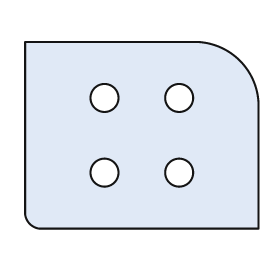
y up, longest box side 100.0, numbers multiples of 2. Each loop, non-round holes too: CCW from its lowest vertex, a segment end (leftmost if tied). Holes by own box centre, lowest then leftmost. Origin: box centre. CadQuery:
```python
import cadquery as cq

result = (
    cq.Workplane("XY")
    .moveTo(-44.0, -40.0)
    .lineTo(50.0, -40.0)
    .lineTo(50.0, 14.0)
    .threePointArc((42.0, 32.0), (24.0, 40.0))
    .lineTo(-50.0, 40.0)
    .lineTo(-50.0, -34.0)
    .threePointArc((-48.0, -38.0), (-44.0, -40.0))
    .close()
    .moveTo(-16.0, -16.0)
    .circle(6.0)
    .moveTo(16.0, -16.0)
    .circle(6.0)
    .moveTo(-16.0, 16.0)
    .circle(6.0)
    .moveTo(16.0, 16.0)
    .circle(6.0)
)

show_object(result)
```